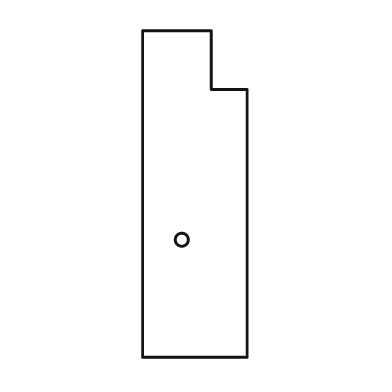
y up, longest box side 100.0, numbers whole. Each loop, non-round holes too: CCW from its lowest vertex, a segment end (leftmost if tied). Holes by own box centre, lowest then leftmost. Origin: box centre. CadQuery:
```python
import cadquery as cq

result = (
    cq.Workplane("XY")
    .moveTo(-16.0, -50.0)
    .lineTo(16.0, -50.0)
    .lineTo(16.0, 32.0)
    .lineTo(5.0, 32.0)
    .lineTo(5.0, 50.0)
    .lineTo(-16.0, 50.0)
    .close()
    .moveTo(-4.0, -14.0)
    .circle(2.0)
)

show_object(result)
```